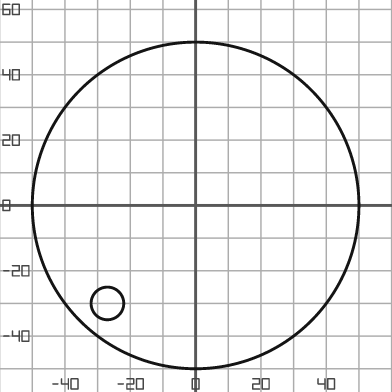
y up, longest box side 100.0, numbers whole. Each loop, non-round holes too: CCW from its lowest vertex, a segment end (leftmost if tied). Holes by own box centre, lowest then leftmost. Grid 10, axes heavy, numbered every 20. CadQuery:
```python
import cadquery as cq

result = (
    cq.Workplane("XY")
    .moveTo(0.0, 0.0)
    .circle(50.0)
    .moveTo(-27.0, -30.0)
    .circle(5.0)
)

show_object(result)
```